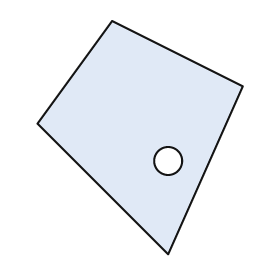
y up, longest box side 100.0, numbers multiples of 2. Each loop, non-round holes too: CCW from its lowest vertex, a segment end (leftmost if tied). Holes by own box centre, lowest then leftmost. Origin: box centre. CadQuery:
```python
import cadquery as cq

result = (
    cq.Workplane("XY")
    .moveTo(12.0, -50.0)
    .lineTo(44.0, 22.0)
    .lineTo(-12.0, 50.0)
    .lineTo(-44.0, 6.0)
    .close()
    .moveTo(12.0, -10.0)
    .circle(6.0)
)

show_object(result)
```